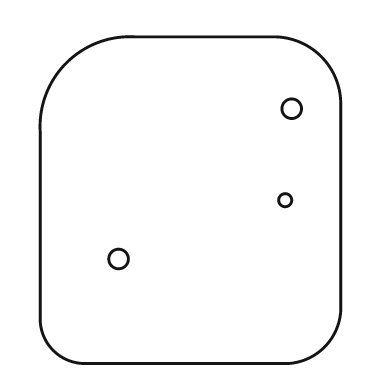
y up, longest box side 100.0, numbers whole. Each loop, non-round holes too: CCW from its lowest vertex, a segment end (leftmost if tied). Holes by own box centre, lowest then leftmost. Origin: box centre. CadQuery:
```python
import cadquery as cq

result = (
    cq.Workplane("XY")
    .moveTo(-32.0, -50.0)
    .lineTo(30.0, -50.0)
    .threePointArc((41.0, -45.0), (46.0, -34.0))
    .lineTo(46.0, 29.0)
    .threePointArc((40.0, 44.0), (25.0, 50.0))
    .lineTo(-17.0, 50.0)
    .threePointArc((-38.0, 42.0), (-46.0, 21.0))
    .lineTo(-46.0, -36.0)
    .threePointArc((-42.0, -46.0), (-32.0, -50.0))
    .close()
    .moveTo(-22.0, -18.0)
    .circle(3.0)
    .moveTo(29.0, 0.0)
    .circle(2.0)
    .moveTo(31.0, 28.0)
    .circle(3.0)
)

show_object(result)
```